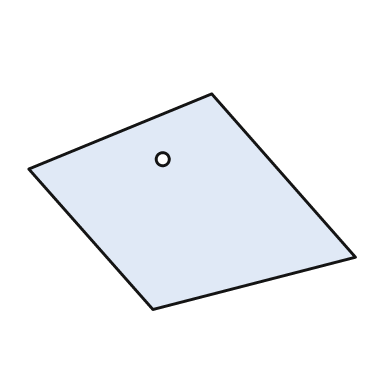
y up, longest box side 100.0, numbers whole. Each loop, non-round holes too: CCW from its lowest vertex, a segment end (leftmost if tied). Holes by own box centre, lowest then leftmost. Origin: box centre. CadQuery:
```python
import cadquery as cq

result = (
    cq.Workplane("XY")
    .moveTo(-12.0, -33.0)
    .lineTo(50.0, -17.0)
    .lineTo(6.0, 33.0)
    .lineTo(-50.0, 10.0)
    .close()
    .moveTo(-9.0, 13.0)
    .circle(2.0)
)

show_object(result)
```